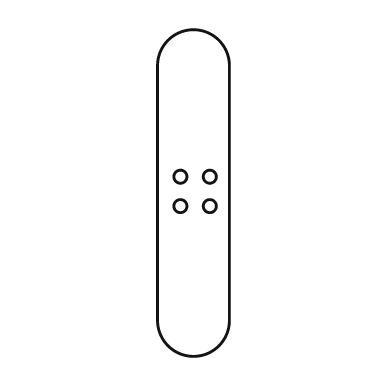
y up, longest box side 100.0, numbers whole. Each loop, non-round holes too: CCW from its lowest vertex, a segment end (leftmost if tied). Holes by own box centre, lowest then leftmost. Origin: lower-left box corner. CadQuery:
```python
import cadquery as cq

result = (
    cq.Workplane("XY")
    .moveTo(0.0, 11.0)
    .threePointArc((11.0, 0.0), (22.0, 11.0))
    .lineTo(22.0, 89.0)
    .threePointArc((11.0, 100.0), (0.0, 89.0))
    .close()
    .moveTo(7.0, 46.0)
    .circle(2.0)
    .moveTo(16.0, 46.0)
    .circle(2.0)
    .moveTo(7.0, 55.0)
    .circle(2.0)
    .moveTo(16.0, 55.0)
    .circle(2.0)
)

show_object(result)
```